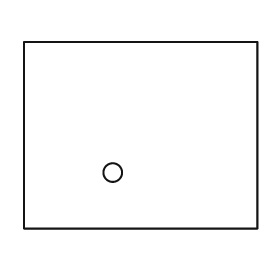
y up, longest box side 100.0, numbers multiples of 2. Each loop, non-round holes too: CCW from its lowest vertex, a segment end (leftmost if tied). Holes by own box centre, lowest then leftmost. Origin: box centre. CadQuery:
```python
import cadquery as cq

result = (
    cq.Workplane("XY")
    .moveTo(-50.0, -40.0)
    .lineTo(50.0, -40.0)
    .lineTo(50.0, 40.0)
    .lineTo(-50.0, 40.0)
    .close()
    .moveTo(-12.0, -16.0)
    .circle(4.0)
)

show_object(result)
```